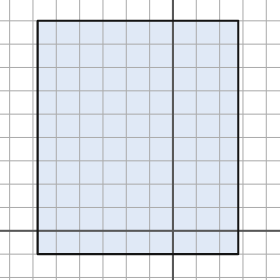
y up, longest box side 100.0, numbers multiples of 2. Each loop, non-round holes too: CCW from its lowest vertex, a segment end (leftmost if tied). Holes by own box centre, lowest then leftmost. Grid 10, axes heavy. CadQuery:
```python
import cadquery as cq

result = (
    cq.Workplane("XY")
    .moveTo(-58.0, -10.0)
    .lineTo(28.0, -10.0)
    .lineTo(28.0, 90.0)
    .lineTo(-58.0, 90.0)
    .close()
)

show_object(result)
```